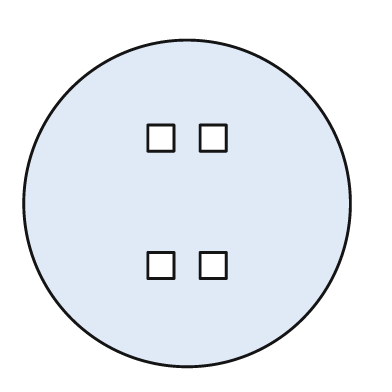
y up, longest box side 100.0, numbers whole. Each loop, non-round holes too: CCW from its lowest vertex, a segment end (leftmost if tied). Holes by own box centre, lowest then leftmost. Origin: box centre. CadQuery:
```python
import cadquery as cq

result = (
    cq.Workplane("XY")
    .moveTo(0.0, 0.0)
    .circle(50.0)
    .moveTo(-12.0, -23.0)
    .lineTo(-4.0, -23.0)
    .lineTo(-4.0, -15.0)
    .lineTo(-12.0, -15.0)
    .close()
    .moveTo(4.0, -23.0)
    .lineTo(12.0, -23.0)
    .lineTo(12.0, -15.0)
    .lineTo(4.0, -15.0)
    .close()
    .moveTo(-12.0, 16.0)
    .lineTo(-4.0, 16.0)
    .lineTo(-4.0, 24.0)
    .lineTo(-12.0, 24.0)
    .close()
    .moveTo(4.0, 16.0)
    .lineTo(12.0, 16.0)
    .lineTo(12.0, 24.0)
    .lineTo(4.0, 24.0)
    .close()
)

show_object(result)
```